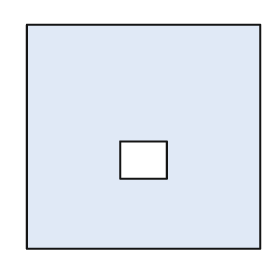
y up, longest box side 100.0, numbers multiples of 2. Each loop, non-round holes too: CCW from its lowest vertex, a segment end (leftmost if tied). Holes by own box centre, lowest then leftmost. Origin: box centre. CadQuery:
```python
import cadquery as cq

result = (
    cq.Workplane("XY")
    .moveTo(-50.0, -48.0)
    .lineTo(50.0, -48.0)
    .lineTo(50.0, 48.0)
    .lineTo(-50.0, 48.0)
    .close()
    .moveTo(-10.0, -18.0)
    .lineTo(10.0, -18.0)
    .lineTo(10.0, -2.0)
    .lineTo(-10.0, -2.0)
    .close()
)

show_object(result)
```